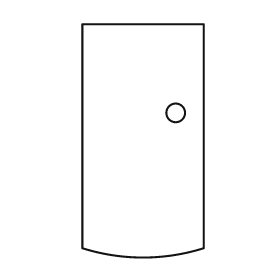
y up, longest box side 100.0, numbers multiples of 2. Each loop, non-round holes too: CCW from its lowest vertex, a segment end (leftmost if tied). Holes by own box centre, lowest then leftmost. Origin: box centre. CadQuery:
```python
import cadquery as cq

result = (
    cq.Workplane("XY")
    .moveTo(-26.0, -46.0)
    .threePointArc((0.0, -50.0), (26.0, -46.0))
    .lineTo(26.0, 50.0)
    .lineTo(-26.0, 50.0)
    .close()
    .moveTo(14.0, 12.0)
    .circle(4.0)
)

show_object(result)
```